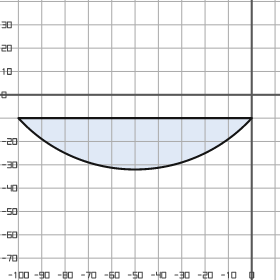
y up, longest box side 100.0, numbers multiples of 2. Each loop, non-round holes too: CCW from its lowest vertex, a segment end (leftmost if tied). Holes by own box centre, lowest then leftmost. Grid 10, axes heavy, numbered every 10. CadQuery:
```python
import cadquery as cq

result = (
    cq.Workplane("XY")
    .moveTo(-100.0, -10.0)
    .threePointArc((-50.0, -32.0), (0.0, -10.0))
    .close()
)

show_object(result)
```